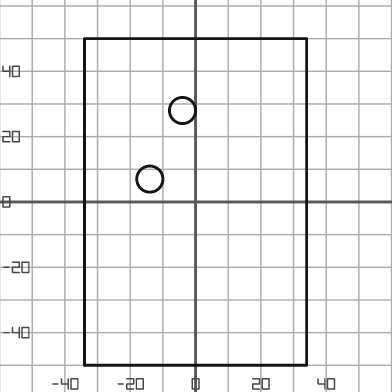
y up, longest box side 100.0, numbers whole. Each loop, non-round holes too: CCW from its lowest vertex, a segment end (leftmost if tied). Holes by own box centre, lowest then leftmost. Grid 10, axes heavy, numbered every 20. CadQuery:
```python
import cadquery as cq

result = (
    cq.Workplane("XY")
    .moveTo(-34.0, -50.0)
    .lineTo(34.0, -50.0)
    .lineTo(34.0, 50.0)
    .lineTo(-34.0, 50.0)
    .close()
    .moveTo(-14.0, 7.0)
    .circle(4.0)
    .moveTo(-4.0, 28.0)
    .circle(4.0)
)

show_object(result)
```